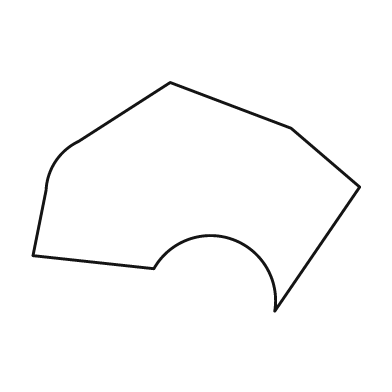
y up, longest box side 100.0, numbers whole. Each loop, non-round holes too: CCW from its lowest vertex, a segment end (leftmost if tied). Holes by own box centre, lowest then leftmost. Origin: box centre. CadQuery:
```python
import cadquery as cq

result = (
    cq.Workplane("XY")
    .moveTo(24.0, -35.0)
    .lineTo(50.0, 3.0)
    .lineTo(29.0, 21.0)
    .lineTo(-8.0, 35.0)
    .lineTo(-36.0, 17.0)
    .threePointArc((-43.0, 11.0), (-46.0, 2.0))
    .lineTo(-50.0, -18.0)
    .lineTo(-13.0, -22.0)
    .threePointArc((11.0, -13.0), (24.0, -35.0))
    .close()
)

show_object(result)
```